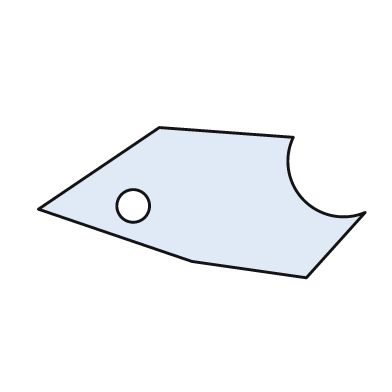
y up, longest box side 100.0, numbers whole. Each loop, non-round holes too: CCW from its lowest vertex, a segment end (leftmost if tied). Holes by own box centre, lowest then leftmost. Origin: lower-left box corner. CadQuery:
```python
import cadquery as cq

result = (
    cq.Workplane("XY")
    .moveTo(82.0, 0.0)
    .lineTo(100.0, 20.0)
    .threePointArc((81.0, 24.0), (78.0, 43.0))
    .lineTo(37.0, 46.0)
    .lineTo(0.0, 21.0)
    .lineTo(47.0, 5.0)
    .close()
    .moveTo(29.0, 22.0)
    .circle(5.0)
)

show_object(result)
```